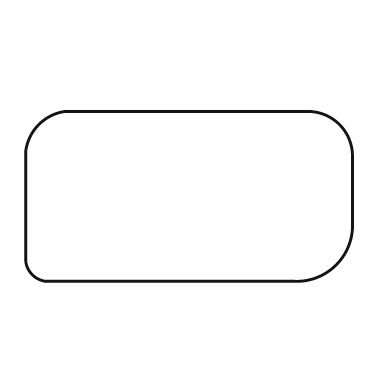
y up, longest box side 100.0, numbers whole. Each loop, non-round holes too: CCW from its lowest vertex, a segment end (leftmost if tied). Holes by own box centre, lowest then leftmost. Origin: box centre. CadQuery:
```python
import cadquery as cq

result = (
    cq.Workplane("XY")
    .moveTo(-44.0, -26.0)
    .lineTo(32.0, -26.0)
    .threePointArc((45.0, -21.0), (50.0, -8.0))
    .lineTo(50.0, 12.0)
    .threePointArc((46.0, 22.0), (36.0, 26.0))
    .lineTo(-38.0, 26.0)
    .threePointArc((-46.0, 22.0), (-50.0, 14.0))
    .lineTo(-50.0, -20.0)
    .threePointArc((-48.0, -24.0), (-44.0, -26.0))
    .close()
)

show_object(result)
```